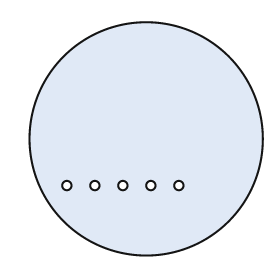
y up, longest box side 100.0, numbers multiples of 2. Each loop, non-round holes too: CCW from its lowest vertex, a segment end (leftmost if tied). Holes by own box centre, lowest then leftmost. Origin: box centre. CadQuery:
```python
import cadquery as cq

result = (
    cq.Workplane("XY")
    .moveTo(0.0, 0.0)
    .circle(50.0)
    .moveTo(-34.0, -20.0)
    .circle(2.0)
    .moveTo(-22.0, -20.0)
    .circle(2.0)
    .moveTo(-10.0, -20.0)
    .circle(2.0)
    .moveTo(2.0, -20.0)
    .circle(2.0)
    .moveTo(14.0, -20.0)
    .circle(2.0)
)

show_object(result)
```